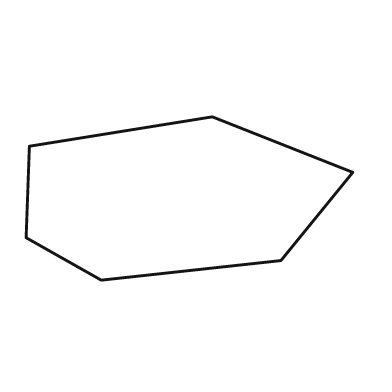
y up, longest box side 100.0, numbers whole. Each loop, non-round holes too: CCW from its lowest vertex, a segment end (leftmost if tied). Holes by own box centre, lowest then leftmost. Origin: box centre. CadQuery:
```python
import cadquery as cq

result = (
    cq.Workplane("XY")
    .moveTo(-27.0, -25.0)
    .lineTo(28.0, -19.0)
    .lineTo(50.0, 8.0)
    .lineTo(7.0, 25.0)
    .lineTo(-49.0, 16.0)
    .lineTo(-50.0, -12.0)
    .close()
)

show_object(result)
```